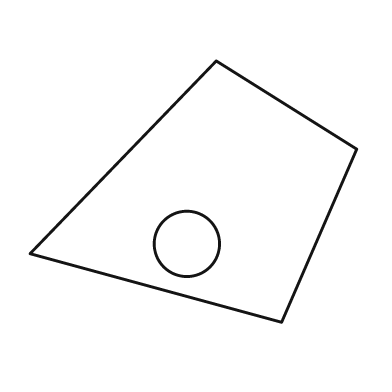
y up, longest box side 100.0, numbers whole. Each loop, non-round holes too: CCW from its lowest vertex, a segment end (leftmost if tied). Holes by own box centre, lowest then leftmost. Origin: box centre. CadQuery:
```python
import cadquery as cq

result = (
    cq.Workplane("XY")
    .moveTo(27.0, -40.0)
    .lineTo(50.0, 13.0)
    .lineTo(7.0, 40.0)
    .lineTo(-50.0, -19.0)
    .close()
    .moveTo(-2.0, -16.0)
    .circle(10.0)
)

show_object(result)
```